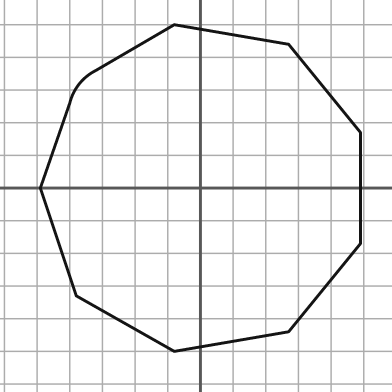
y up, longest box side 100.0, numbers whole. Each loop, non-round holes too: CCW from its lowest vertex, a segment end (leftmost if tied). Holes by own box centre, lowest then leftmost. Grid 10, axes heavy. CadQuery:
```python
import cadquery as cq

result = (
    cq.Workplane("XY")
    .moveTo(-8.0, -50.0)
    .lineTo(27.0, -44.0)
    .lineTo(49.0, -17.0)
    .lineTo(49.0, 17.0)
    .lineTo(27.0, 44.0)
    .lineTo(-8.0, 50.0)
    .lineTo(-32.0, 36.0)
    .threePointArc((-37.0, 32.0), (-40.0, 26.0))
    .lineTo(-49.0, 0.0)
    .lineTo(-38.0, -33.0)
    .close()
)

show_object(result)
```